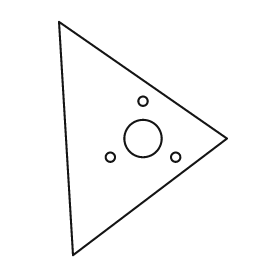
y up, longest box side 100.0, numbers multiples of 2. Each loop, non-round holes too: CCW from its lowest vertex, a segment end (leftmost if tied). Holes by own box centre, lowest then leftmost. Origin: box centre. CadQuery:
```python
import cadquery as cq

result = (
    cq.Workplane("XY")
    .moveTo(-30.0, -50.0)
    .lineTo(36.0, 0.0)
    .lineTo(-36.0, 50.0)
    .close()
    .moveTo(-14.0, -8.0)
    .circle(2.0)
    .moveTo(14.0, -8.0)
    .circle(2.0)
    .moveTo(0.0, 0.0)
    .circle(8.0)
    .moveTo(0.0, 16.0)
    .circle(2.0)
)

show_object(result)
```